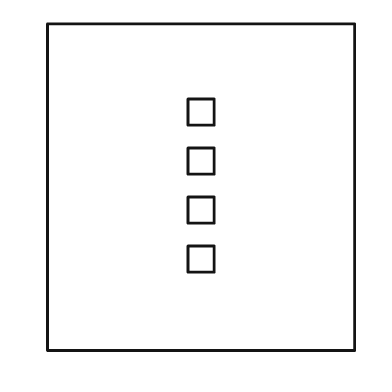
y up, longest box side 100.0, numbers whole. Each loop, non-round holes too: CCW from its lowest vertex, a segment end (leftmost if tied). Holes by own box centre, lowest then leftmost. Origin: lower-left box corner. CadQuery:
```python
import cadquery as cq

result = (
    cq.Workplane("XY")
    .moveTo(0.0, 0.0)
    .lineTo(94.0, 0.0)
    .lineTo(94.0, 100.0)
    .lineTo(0.0, 100.0)
    .close()
    .moveTo(43.0, 24.0)
    .lineTo(51.0, 24.0)
    .lineTo(51.0, 32.0)
    .lineTo(43.0, 32.0)
    .close()
    .moveTo(43.0, 39.0)
    .lineTo(51.0, 39.0)
    .lineTo(51.0, 47.0)
    .lineTo(43.0, 47.0)
    .close()
    .moveTo(43.0, 54.0)
    .lineTo(51.0, 54.0)
    .lineTo(51.0, 62.0)
    .lineTo(43.0, 62.0)
    .close()
    .moveTo(43.0, 69.0)
    .lineTo(51.0, 69.0)
    .lineTo(51.0, 77.0)
    .lineTo(43.0, 77.0)
    .close()
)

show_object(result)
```